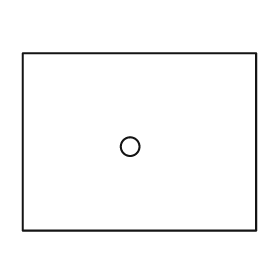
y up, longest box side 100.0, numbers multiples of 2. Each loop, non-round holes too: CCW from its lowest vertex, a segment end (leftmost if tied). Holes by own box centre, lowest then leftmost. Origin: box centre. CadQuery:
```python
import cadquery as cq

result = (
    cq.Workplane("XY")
    .moveTo(-50.0, -38.0)
    .lineTo(50.0, -38.0)
    .lineTo(50.0, 38.0)
    .lineTo(-50.0, 38.0)
    .close()
    .moveTo(-4.0, -2.0)
    .circle(4.0)
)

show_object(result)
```